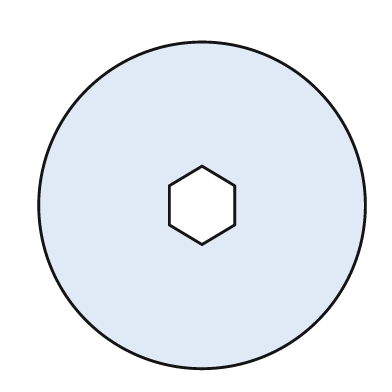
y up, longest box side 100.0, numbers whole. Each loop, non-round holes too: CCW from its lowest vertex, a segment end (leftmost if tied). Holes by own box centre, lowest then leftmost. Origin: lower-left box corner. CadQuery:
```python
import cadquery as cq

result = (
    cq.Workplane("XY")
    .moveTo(50.0, 50.0)
    .circle(50.0)
    .moveTo(50.0, 38.0)
    .lineTo(60.0, 44.0)
    .lineTo(60.0, 56.0)
    .lineTo(50.0, 62.0)
    .lineTo(40.0, 56.0)
    .lineTo(40.0, 44.0)
    .close()
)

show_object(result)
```